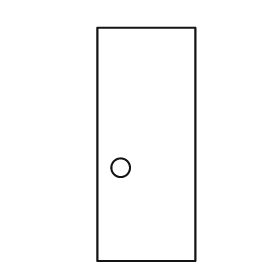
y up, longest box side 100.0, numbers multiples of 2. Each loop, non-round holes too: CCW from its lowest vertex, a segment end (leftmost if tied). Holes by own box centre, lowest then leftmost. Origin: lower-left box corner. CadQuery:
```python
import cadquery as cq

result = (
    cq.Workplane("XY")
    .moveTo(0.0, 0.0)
    .lineTo(42.0, 0.0)
    .lineTo(42.0, 100.0)
    .lineTo(0.0, 100.0)
    .close()
    .moveTo(10.0, 40.0)
    .circle(4.0)
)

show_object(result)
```